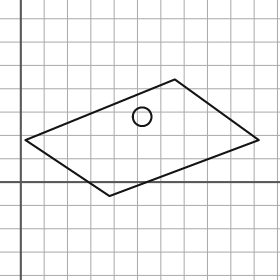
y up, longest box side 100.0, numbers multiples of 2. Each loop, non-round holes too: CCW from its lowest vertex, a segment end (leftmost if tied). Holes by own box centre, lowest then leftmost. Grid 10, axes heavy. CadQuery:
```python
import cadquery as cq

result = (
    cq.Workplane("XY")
    .moveTo(38.0, -6.0)
    .lineTo(102.0, 18.0)
    .lineTo(66.0, 44.0)
    .lineTo(2.0, 18.0)
    .close()
    .moveTo(52.0, 28.0)
    .circle(4.0)
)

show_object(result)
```